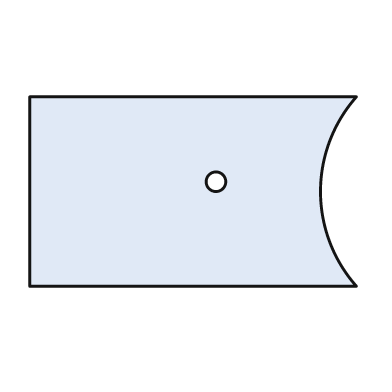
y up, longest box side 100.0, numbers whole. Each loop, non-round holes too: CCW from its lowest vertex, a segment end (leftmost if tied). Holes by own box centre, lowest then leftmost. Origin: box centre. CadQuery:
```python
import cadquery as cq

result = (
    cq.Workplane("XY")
    .moveTo(-50.0, -29.0)
    .lineTo(50.0, -29.0)
    .threePointArc((39.0, 0.0), (50.0, 29.0))
    .lineTo(-50.0, 29.0)
    .close()
    .moveTo(7.0, 3.0)
    .circle(3.0)
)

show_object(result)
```